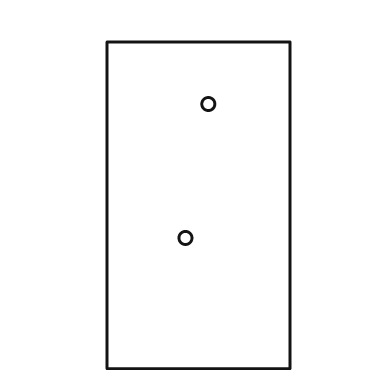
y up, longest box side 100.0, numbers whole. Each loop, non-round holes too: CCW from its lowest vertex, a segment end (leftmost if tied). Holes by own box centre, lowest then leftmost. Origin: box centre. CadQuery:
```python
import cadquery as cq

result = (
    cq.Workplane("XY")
    .moveTo(-28.0, -50.0)
    .lineTo(28.0, -50.0)
    .lineTo(28.0, 50.0)
    .lineTo(-28.0, 50.0)
    .close()
    .moveTo(-4.0, -10.0)
    .circle(2.0)
    .moveTo(3.0, 31.0)
    .circle(2.0)
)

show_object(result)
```